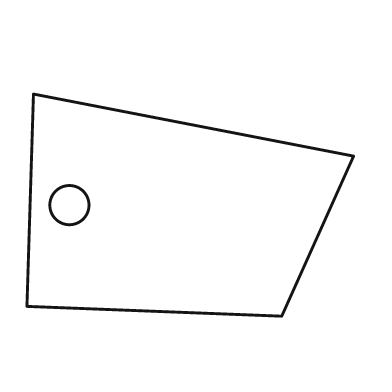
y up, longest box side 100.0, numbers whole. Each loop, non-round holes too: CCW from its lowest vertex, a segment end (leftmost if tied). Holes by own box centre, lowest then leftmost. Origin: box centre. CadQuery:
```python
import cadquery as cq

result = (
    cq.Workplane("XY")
    .moveTo(28.0, -34.0)
    .lineTo(50.0, 15.0)
    .lineTo(-48.0, 34.0)
    .lineTo(-50.0, -31.0)
    .close()
    .moveTo(-37.0, 0.0)
    .circle(6.0)
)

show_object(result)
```